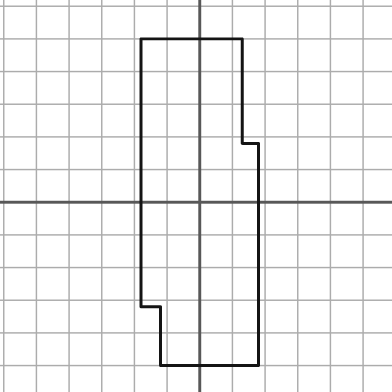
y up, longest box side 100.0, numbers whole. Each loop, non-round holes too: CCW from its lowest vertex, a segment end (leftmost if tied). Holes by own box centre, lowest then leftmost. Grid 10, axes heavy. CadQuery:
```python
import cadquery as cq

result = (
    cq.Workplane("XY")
    .moveTo(-12.0, -50.0)
    .lineTo(18.0, -50.0)
    .lineTo(18.0, 18.0)
    .lineTo(13.0, 18.0)
    .lineTo(13.0, 50.0)
    .lineTo(-18.0, 50.0)
    .lineTo(-18.0, -32.0)
    .lineTo(-12.0, -32.0)
    .close()
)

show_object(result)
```